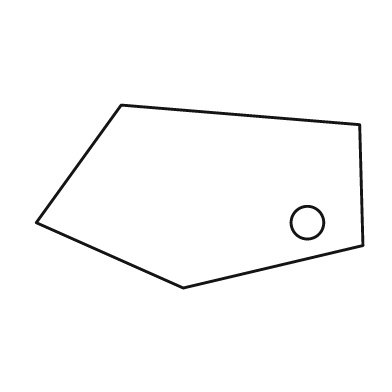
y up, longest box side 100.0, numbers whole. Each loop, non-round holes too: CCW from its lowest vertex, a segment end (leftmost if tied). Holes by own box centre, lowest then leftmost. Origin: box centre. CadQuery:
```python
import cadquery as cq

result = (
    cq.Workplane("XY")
    .moveTo(-5.0, -28.0)
    .lineTo(50.0, -15.0)
    .lineTo(49.0, 22.0)
    .lineTo(-24.0, 28.0)
    .lineTo(-50.0, -8.0)
    .close()
    .moveTo(33.0, -8.0)
    .circle(5.0)
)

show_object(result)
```